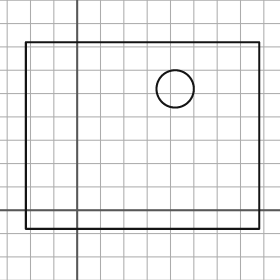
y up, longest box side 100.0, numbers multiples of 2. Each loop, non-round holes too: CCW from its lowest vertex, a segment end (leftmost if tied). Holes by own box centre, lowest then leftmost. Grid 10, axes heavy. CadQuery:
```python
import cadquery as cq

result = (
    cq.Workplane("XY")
    .moveTo(-22.0, -8.0)
    .lineTo(78.0, -8.0)
    .lineTo(78.0, 72.0)
    .lineTo(-22.0, 72.0)
    .close()
    .moveTo(42.0, 52.0)
    .circle(8.0)
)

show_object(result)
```